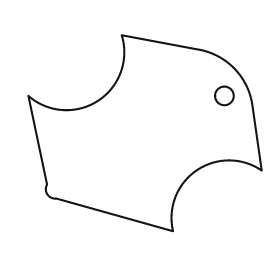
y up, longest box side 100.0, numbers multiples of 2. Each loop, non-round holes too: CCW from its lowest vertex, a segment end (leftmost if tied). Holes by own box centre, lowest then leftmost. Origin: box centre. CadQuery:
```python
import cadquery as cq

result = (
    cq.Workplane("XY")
    .moveTo(12.0, -42.0)
    .threePointArc((22.0, -16.0), (50.0, -16.0))
    .lineTo(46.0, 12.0)
    .threePointArc((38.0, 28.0), (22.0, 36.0))
    .lineTo(-10.0, 42.0)
    .threePointArc((-20.0, 14.0), (-50.0, 16.0))
    .lineTo(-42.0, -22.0)
    .threePointArc((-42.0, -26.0), (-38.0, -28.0))
    .close()
    .moveTo(34.0, 16.0)
    .circle(4.0)
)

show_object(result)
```